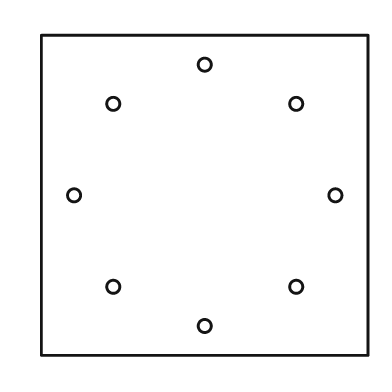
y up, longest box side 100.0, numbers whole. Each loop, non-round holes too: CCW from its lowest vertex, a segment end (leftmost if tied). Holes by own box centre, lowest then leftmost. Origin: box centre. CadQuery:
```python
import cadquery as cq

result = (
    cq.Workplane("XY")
    .moveTo(-50.0, -49.0)
    .lineTo(50.0, -49.0)
    .lineTo(50.0, 49.0)
    .lineTo(-50.0, 49.0)
    .close()
    .moveTo(0.0, -40.0)
    .circle(2.0)
    .moveTo(-28.0, -28.0)
    .circle(2.0)
    .moveTo(28.0, -28.0)
    .circle(2.0)
    .moveTo(-40.0, 0.0)
    .circle(2.0)
    .moveTo(40.0, 0.0)
    .circle(2.0)
    .moveTo(-28.0, 28.0)
    .circle(2.0)
    .moveTo(28.0, 28.0)
    .circle(2.0)
    .moveTo(0.0, 40.0)
    .circle(2.0)
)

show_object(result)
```